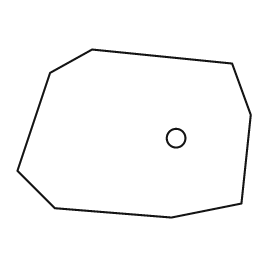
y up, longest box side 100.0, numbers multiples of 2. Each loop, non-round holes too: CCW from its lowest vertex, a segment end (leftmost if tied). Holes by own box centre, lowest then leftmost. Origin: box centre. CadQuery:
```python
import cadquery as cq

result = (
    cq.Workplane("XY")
    .moveTo(16.0, -36.0)
    .lineTo(46.0, -30.0)
    .lineTo(50.0, 8.0)
    .lineTo(42.0, 30.0)
    .lineTo(-18.0, 36.0)
    .lineTo(-36.0, 26.0)
    .lineTo(-50.0, -16.0)
    .lineTo(-34.0, -32.0)
    .close()
    .moveTo(18.0, -2.0)
    .circle(4.0)
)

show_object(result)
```